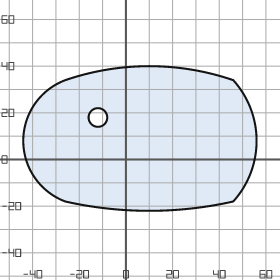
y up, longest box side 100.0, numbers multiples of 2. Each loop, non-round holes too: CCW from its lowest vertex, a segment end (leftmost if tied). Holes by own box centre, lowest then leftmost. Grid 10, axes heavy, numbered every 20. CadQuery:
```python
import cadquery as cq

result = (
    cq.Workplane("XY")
    .moveTo(-26.0, -18.0)
    .threePointArc((10.0, -22.0), (46.0, -18.0))
    .threePointArc((56.0, 8.0), (46.0, 34.0))
    .threePointArc((10.0, 40.0), (-26.0, 34.0))
    .threePointArc((-44.0, 8.0), (-26.0, -18.0))
    .close()
    .moveTo(-12.0, 18.0)
    .circle(4.0)
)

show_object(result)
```